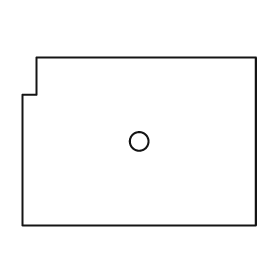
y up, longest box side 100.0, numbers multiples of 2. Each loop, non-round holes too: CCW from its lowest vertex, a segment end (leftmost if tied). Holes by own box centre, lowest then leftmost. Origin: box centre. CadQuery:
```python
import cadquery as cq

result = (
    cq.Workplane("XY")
    .moveTo(-50.0, -36.0)
    .lineTo(50.0, -36.0)
    .lineTo(50.0, 36.0)
    .lineTo(-44.0, 36.0)
    .lineTo(-44.0, 20.0)
    .lineTo(-50.0, 20.0)
    .close()
    .moveTo(0.0, 0.0)
    .circle(4.0)
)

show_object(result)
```